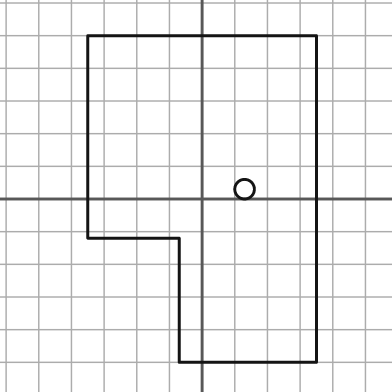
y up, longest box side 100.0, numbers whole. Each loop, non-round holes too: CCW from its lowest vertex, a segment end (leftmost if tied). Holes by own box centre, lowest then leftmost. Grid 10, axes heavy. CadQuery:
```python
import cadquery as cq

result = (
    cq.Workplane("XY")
    .moveTo(-7.0, -50.0)
    .lineTo(35.0, -50.0)
    .lineTo(35.0, 50.0)
    .lineTo(-35.0, 50.0)
    .lineTo(-35.0, -12.0)
    .lineTo(-7.0, -12.0)
    .close()
    .moveTo(13.0, 3.0)
    .circle(3.0)
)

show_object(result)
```